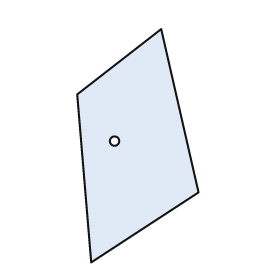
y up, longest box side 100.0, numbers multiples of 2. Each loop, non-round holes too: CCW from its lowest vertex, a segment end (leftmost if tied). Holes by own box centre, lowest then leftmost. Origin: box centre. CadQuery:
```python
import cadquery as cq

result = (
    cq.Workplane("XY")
    .moveTo(-20.0, -50.0)
    .lineTo(26.0, -20.0)
    .lineTo(10.0, 50.0)
    .lineTo(-26.0, 22.0)
    .close()
    .moveTo(-10.0, 2.0)
    .circle(2.0)
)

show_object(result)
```